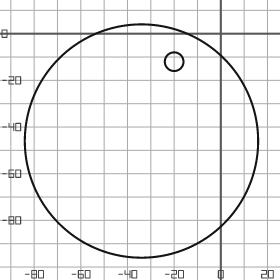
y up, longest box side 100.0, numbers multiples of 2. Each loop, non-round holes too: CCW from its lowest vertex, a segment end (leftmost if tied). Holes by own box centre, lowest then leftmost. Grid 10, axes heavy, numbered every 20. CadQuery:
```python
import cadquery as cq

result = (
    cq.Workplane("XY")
    .moveTo(-34.0, -46.0)
    .circle(50.0)
    .moveTo(-20.0, -12.0)
    .circle(4.0)
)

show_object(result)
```